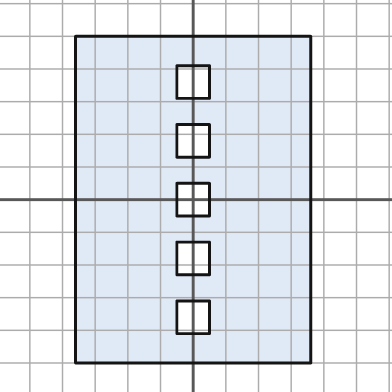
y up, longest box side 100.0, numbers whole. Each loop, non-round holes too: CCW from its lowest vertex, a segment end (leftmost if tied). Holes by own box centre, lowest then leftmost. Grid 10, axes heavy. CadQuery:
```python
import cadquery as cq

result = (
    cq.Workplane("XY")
    .moveTo(-36.0, -50.0)
    .lineTo(36.0, -50.0)
    .lineTo(36.0, 50.0)
    .lineTo(-36.0, 50.0)
    .close()
    .moveTo(-5.0, -41.0)
    .lineTo(5.0, -41.0)
    .lineTo(5.0, -31.0)
    .lineTo(-5.0, -31.0)
    .close()
    .moveTo(-5.0, -23.0)
    .lineTo(5.0, -23.0)
    .lineTo(5.0, -13.0)
    .lineTo(-5.0, -13.0)
    .close()
    .moveTo(-5.0, -5.0)
    .lineTo(5.0, -5.0)
    .lineTo(5.0, 5.0)
    .lineTo(-5.0, 5.0)
    .close()
    .moveTo(-5.0, 13.0)
    .lineTo(5.0, 13.0)
    .lineTo(5.0, 23.0)
    .lineTo(-5.0, 23.0)
    .close()
    .moveTo(-5.0, 31.0)
    .lineTo(5.0, 31.0)
    .lineTo(5.0, 41.0)
    .lineTo(-5.0, 41.0)
    .close()
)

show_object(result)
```